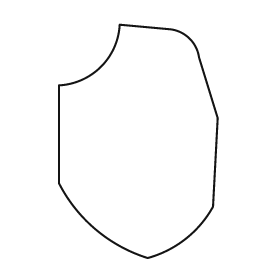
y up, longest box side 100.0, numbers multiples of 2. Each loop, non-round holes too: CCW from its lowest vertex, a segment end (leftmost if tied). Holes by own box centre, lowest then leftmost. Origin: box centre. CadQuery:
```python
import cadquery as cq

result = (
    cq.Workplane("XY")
    .moveTo(4.0, -50.0)
    .threePointArc((20.0, -42.0), (32.0, -28.0))
    .lineTo(34.0, 10.0)
    .lineTo(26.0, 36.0)
    .threePointArc((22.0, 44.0), (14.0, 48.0))
    .lineTo(-8.0, 50.0)
    .threePointArc((-16.0, 32.0), (-34.0, 24.0))
    .lineTo(-34.0, -18.0)
    .threePointArc((-18.0, -38.0), (4.0, -50.0))
    .close()
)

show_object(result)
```